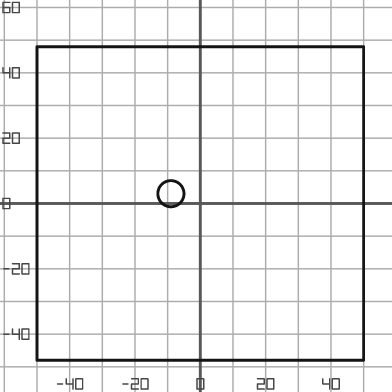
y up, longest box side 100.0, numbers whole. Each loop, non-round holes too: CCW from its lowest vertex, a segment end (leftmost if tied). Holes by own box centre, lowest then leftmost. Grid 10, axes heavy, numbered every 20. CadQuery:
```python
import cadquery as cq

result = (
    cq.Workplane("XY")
    .moveTo(-50.0, -48.0)
    .lineTo(50.0, -48.0)
    .lineTo(50.0, 48.0)
    .lineTo(-50.0, 48.0)
    .close()
    .moveTo(-9.0, 3.0)
    .circle(4.0)
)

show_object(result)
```